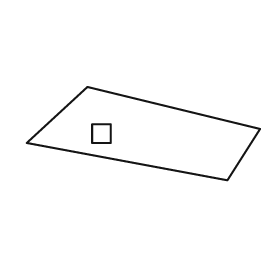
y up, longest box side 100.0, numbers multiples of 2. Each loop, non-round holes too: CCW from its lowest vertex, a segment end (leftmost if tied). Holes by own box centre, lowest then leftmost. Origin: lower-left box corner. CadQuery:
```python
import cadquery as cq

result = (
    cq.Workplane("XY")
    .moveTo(86.0, 0.0)
    .lineTo(100.0, 22.0)
    .lineTo(26.0, 40.0)
    .lineTo(0.0, 16.0)
    .close()
    .moveTo(28.0, 16.0)
    .lineTo(36.0, 16.0)
    .lineTo(36.0, 24.0)
    .lineTo(28.0, 24.0)
    .close()
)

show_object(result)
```